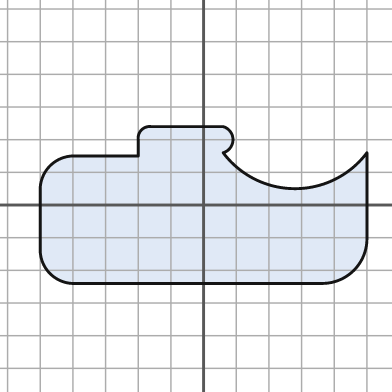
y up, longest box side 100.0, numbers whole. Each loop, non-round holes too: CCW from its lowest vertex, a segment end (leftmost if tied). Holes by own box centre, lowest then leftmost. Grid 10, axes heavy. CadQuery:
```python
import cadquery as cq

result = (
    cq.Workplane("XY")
    .moveTo(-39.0, -24.0)
    .lineTo(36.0, -24.0)
    .threePointArc((46.0, -20.0), (50.0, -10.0))
    .lineTo(50.0, 16.0)
    .threePointArc((28.0, 5.0), (6.0, 16.0))
    .threePointArc((9.0, 20.0), (6.0, 24.0))
    .lineTo(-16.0, 24.0)
    .threePointArc((-19.0, 23.0), (-20.0, 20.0))
    .lineTo(-20.0, 15.0)
    .lineTo(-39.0, 15.0)
    .threePointArc((-47.0, 12.0), (-50.0, 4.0))
    .lineTo(-50.0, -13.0)
    .threePointArc((-47.0, -21.0), (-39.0, -24.0))
    .close()
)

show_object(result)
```